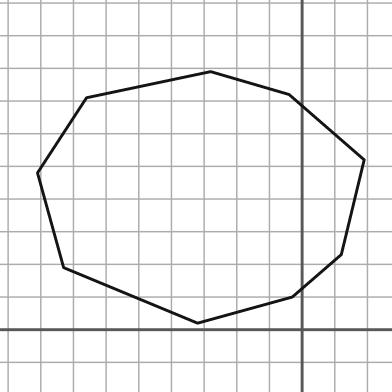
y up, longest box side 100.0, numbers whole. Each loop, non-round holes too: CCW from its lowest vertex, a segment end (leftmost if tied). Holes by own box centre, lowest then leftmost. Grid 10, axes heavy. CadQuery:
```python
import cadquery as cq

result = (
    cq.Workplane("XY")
    .moveTo(-32.0, 2.0)
    .lineTo(-3.0, 10.0)
    .lineTo(12.0, 23.0)
    .lineTo(19.0, 52.0)
    .lineTo(-4.0, 72.0)
    .lineTo(-28.0, 79.0)
    .lineTo(-66.0, 71.0)
    .lineTo(-81.0, 48.0)
    .lineTo(-73.0, 19.0)
    .close()
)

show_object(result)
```